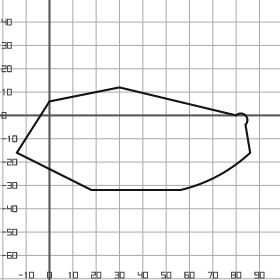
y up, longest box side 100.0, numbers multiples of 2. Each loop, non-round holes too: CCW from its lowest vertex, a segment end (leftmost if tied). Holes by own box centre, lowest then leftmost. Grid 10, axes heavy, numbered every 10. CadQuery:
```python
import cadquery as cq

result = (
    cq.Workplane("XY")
    .moveTo(18.0, -32.0)
    .lineTo(56.0, -32.0)
    .threePointArc((72.0, -26.0), (86.0, -16.0))
    .lineTo(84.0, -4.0)
    .threePointArc((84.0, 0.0), (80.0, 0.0))
    .lineTo(30.0, 12.0)
    .lineTo(0.0, 6.0)
    .lineTo(-14.0, -16.0)
    .close()
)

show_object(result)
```